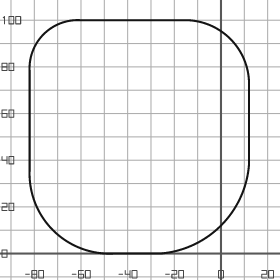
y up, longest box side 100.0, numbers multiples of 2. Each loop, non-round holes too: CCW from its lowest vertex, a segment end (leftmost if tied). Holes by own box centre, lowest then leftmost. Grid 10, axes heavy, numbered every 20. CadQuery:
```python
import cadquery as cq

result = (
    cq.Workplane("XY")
    .moveTo(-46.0, 0.0)
    .lineTo(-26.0, 0.0)
    .threePointArc((0.0, 12.0), (12.0, 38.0))
    .lineTo(12.0, 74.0)
    .threePointArc((4.0, 92.0), (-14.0, 100.0))
    .lineTo(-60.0, 100.0)
    .threePointArc((-76.0, 94.0), (-82.0, 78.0))
    .lineTo(-82.0, 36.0)
    .threePointArc((-72.0, 10.0), (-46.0, 0.0))
    .close()
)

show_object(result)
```